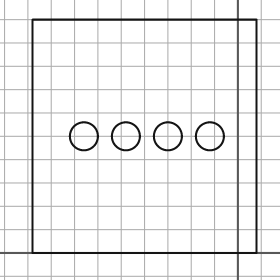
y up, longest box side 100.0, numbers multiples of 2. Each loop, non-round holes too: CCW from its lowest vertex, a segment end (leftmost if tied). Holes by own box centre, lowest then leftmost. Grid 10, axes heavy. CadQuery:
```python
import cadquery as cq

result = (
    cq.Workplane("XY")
    .moveTo(-88.0, 0.0)
    .lineTo(8.0, 0.0)
    .lineTo(8.0, 100.0)
    .lineTo(-88.0, 100.0)
    .close()
    .moveTo(-66.0, 50.0)
    .circle(6.0)
    .moveTo(-48.0, 50.0)
    .circle(6.0)
    .moveTo(-30.0, 50.0)
    .circle(6.0)
    .moveTo(-12.0, 50.0)
    .circle(6.0)
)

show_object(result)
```